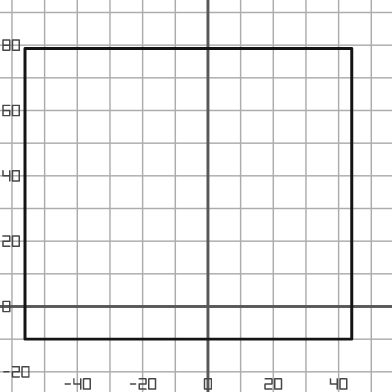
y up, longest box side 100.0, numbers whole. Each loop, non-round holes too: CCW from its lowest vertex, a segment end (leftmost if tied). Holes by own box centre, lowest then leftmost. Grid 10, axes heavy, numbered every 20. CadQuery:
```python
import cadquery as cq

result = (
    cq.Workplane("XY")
    .moveTo(-56.0, -10.0)
    .lineTo(44.0, -10.0)
    .lineTo(44.0, 79.0)
    .lineTo(-56.0, 79.0)
    .close()
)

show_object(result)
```